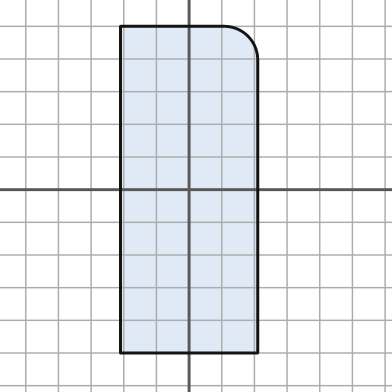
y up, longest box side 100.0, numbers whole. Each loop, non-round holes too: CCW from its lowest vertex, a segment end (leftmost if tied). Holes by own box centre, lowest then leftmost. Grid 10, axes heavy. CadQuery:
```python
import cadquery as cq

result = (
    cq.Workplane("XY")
    .moveTo(-21.0, -50.0)
    .lineTo(21.0, -50.0)
    .lineTo(21.0, 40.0)
    .threePointArc((18.0, 47.0), (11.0, 50.0))
    .lineTo(-21.0, 50.0)
    .close()
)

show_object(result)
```